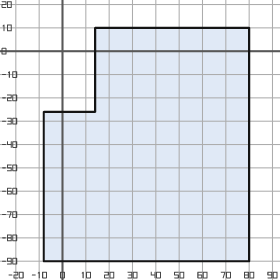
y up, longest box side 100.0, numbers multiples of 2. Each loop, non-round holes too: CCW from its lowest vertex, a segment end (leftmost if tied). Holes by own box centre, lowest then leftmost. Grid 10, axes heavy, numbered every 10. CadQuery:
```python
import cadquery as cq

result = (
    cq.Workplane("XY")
    .moveTo(-8.0, -90.0)
    .lineTo(80.0, -90.0)
    .lineTo(80.0, 10.0)
    .lineTo(14.0, 10.0)
    .lineTo(14.0, -26.0)
    .lineTo(-8.0, -26.0)
    .close()
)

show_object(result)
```